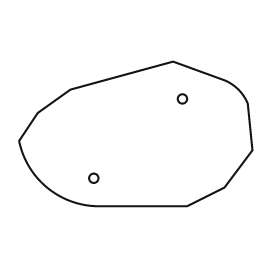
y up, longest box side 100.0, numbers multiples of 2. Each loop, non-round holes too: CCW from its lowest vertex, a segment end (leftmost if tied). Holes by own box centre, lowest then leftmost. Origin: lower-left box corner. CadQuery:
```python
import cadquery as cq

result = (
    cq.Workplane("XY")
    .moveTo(34.0, 0.0)
    .lineTo(72.0, 0.0)
    .lineTo(88.0, 8.0)
    .lineTo(100.0, 24.0)
    .lineTo(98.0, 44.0)
    .threePointArc((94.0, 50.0), (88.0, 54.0))
    .lineTo(66.0, 62.0)
    .lineTo(22.0, 50.0)
    .lineTo(8.0, 40.0)
    .lineTo(0.0, 28.0)
    .threePointArc((12.0, 8.0), (34.0, 0.0))
    .close()
    .moveTo(32.0, 12.0)
    .circle(2.0)
    .moveTo(70.0, 46.0)
    .circle(2.0)
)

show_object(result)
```